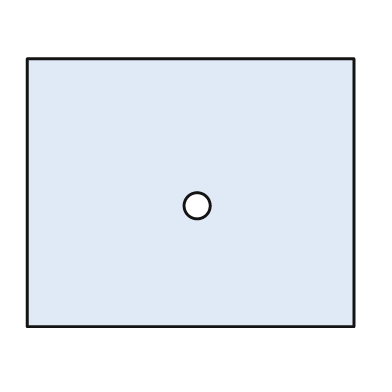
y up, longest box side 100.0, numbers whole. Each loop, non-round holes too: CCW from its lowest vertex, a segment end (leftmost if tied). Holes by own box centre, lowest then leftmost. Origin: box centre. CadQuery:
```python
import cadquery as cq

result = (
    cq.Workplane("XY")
    .moveTo(-50.0, -41.0)
    .lineTo(50.0, -41.0)
    .lineTo(50.0, 41.0)
    .lineTo(-50.0, 41.0)
    .close()
    .moveTo(2.0, -4.0)
    .circle(4.0)
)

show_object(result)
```